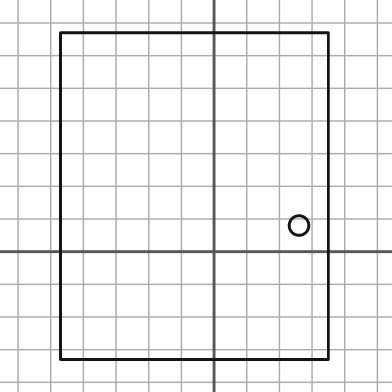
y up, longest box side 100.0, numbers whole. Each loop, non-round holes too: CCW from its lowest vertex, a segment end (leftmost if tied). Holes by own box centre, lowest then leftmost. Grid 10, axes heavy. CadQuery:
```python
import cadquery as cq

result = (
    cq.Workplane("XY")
    .moveTo(-47.0, -33.0)
    .lineTo(35.0, -33.0)
    .lineTo(35.0, 67.0)
    .lineTo(-47.0, 67.0)
    .close()
    .moveTo(26.0, 8.0)
    .circle(3.0)
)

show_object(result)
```